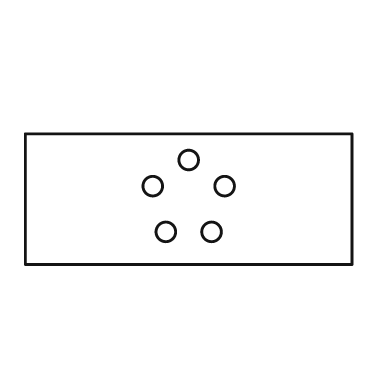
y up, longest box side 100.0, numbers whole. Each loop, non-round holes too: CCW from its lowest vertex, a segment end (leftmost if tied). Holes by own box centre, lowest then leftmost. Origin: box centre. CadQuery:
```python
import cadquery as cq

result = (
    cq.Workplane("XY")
    .moveTo(-50.0, -20.0)
    .lineTo(50.0, -20.0)
    .lineTo(50.0, 20.0)
    .lineTo(-50.0, 20.0)
    .close()
    .moveTo(-7.0, -10.0)
    .circle(3.0)
    .moveTo(7.0, -10.0)
    .circle(3.0)
    .moveTo(-11.0, 4.0)
    .circle(3.0)
    .moveTo(11.0, 4.0)
    .circle(3.0)
    .moveTo(0.0, 12.0)
    .circle(3.0)
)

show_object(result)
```